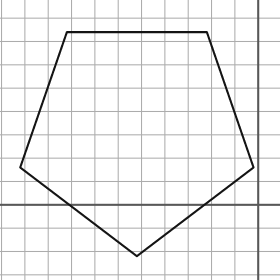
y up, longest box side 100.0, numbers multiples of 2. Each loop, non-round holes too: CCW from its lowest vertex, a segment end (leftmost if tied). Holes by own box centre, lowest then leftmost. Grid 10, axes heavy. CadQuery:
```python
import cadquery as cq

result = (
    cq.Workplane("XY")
    .moveTo(-52.0, -22.0)
    .lineTo(-2.0, 16.0)
    .lineTo(-22.0, 74.0)
    .lineTo(-82.0, 74.0)
    .lineTo(-102.0, 16.0)
    .close()
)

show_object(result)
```